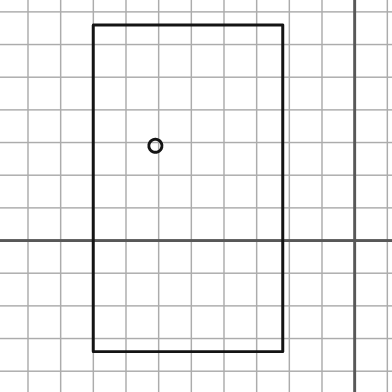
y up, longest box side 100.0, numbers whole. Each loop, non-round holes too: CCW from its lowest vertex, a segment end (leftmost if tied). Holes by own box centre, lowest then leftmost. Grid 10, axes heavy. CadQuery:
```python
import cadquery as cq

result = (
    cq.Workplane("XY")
    .moveTo(-80.0, -34.0)
    .lineTo(-22.0, -34.0)
    .lineTo(-22.0, 66.0)
    .lineTo(-80.0, 66.0)
    .close()
    .moveTo(-61.0, 29.0)
    .circle(2.0)
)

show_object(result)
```